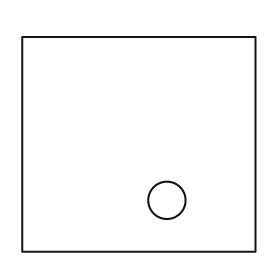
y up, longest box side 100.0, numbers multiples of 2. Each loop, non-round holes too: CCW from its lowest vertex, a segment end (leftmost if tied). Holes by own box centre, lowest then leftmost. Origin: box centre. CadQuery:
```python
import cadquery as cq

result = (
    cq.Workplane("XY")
    .moveTo(-50.0, -46.0)
    .lineTo(50.0, -46.0)
    .lineTo(50.0, 46.0)
    .lineTo(-50.0, 46.0)
    .close()
    .moveTo(12.0, -24.0)
    .circle(8.0)
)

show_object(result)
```